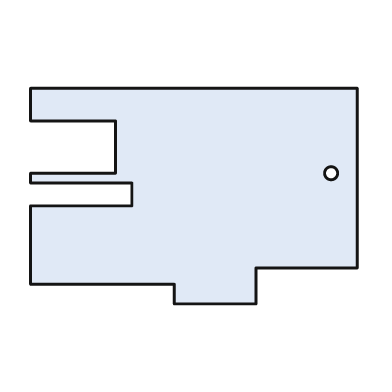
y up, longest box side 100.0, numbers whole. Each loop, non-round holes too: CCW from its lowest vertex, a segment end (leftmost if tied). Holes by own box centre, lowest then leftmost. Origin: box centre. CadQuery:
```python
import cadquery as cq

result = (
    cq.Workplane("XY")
    .moveTo(-6.0, -33.0)
    .lineTo(19.0, -33.0)
    .lineTo(19.0, -22.0)
    .lineTo(50.0, -22.0)
    .lineTo(50.0, 33.0)
    .lineTo(-50.0, 33.0)
    .lineTo(-50.0, 23.0)
    .lineTo(-24.0, 23.0)
    .lineTo(-24.0, 7.0)
    .lineTo(-50.0, 7.0)
    .lineTo(-50.0, 4.0)
    .lineTo(-19.0, 4.0)
    .lineTo(-19.0, -3.0)
    .lineTo(-50.0, -3.0)
    .lineTo(-50.0, -27.0)
    .lineTo(-6.0, -27.0)
    .close()
    .moveTo(42.0, 7.0)
    .circle(2.0)
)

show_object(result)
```